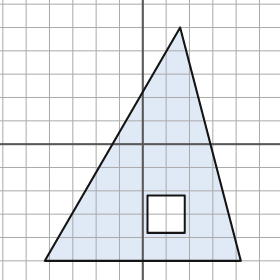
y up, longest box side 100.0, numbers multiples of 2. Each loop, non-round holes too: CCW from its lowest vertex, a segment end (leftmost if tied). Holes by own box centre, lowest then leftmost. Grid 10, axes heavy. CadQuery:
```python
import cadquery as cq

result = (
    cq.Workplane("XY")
    .moveTo(-42.0, -50.0)
    .lineTo(42.0, -50.0)
    .lineTo(16.0, 50.0)
    .close()
    .moveTo(2.0, -38.0)
    .lineTo(18.0, -38.0)
    .lineTo(18.0, -22.0)
    .lineTo(2.0, -22.0)
    .close()
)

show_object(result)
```